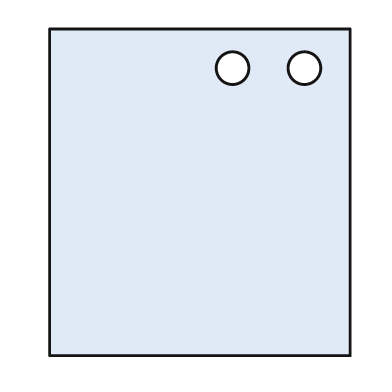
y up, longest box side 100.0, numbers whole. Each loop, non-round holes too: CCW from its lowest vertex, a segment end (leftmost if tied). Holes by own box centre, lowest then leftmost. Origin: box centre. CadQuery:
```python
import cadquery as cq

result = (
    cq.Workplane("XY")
    .moveTo(-46.0, -50.0)
    .lineTo(46.0, -50.0)
    .lineTo(46.0, 50.0)
    .lineTo(-46.0, 50.0)
    .close()
    .moveTo(10.0, 38.0)
    .circle(5.0)
    .moveTo(32.0, 38.0)
    .circle(5.0)
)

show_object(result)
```